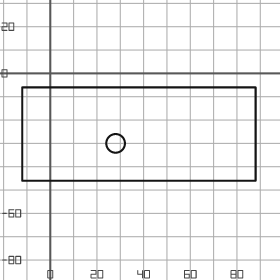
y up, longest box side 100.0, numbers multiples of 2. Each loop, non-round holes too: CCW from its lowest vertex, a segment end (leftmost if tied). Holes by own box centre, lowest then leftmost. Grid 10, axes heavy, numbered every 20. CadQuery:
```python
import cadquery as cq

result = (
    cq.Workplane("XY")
    .moveTo(-12.0, -46.0)
    .lineTo(88.0, -46.0)
    .lineTo(88.0, -6.0)
    .lineTo(-12.0, -6.0)
    .close()
    .moveTo(28.0, -30.0)
    .circle(4.0)
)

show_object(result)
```